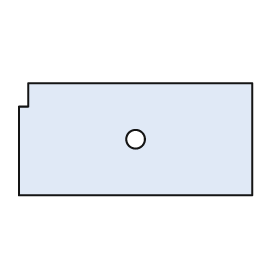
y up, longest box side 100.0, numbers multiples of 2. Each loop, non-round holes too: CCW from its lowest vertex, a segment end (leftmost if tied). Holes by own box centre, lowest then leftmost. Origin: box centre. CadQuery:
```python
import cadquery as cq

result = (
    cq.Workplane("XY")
    .moveTo(-50.0, -24.0)
    .lineTo(50.0, -24.0)
    .lineTo(50.0, 24.0)
    .lineTo(-46.0, 24.0)
    .lineTo(-46.0, 14.0)
    .lineTo(-50.0, 14.0)
    .close()
    .moveTo(0.0, 0.0)
    .circle(4.0)
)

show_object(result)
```